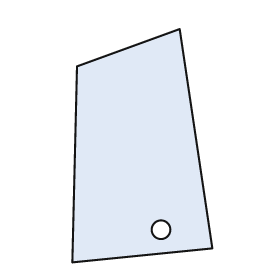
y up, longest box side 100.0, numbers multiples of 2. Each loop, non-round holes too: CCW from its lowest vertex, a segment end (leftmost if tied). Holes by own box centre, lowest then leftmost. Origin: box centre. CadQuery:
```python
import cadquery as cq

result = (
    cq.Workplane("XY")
    .moveTo(-30.0, -50.0)
    .lineTo(30.0, -44.0)
    .lineTo(16.0, 50.0)
    .lineTo(-28.0, 34.0)
    .close()
    .moveTo(8.0, -36.0)
    .circle(4.0)
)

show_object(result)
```